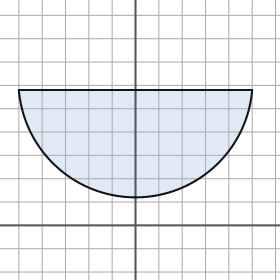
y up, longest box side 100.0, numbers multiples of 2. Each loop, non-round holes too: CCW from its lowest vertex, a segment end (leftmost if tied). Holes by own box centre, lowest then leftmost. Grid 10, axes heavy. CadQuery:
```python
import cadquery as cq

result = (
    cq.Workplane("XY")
    .moveTo(-50.0, 58.0)
    .threePointArc((0.0, 12.0), (50.0, 58.0))
    .close()
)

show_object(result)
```